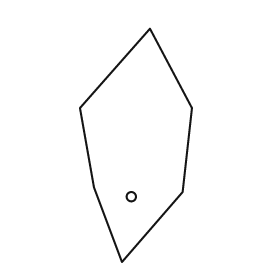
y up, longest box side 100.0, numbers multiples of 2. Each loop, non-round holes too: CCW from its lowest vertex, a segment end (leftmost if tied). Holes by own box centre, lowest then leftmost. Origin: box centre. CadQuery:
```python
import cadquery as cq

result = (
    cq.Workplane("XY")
    .moveTo(-6.0, -50.0)
    .lineTo(20.0, -20.0)
    .lineTo(24.0, 16.0)
    .lineTo(6.0, 50.0)
    .lineTo(-24.0, 16.0)
    .lineTo(-18.0, -18.0)
    .close()
    .moveTo(-2.0, -22.0)
    .circle(2.0)
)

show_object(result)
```